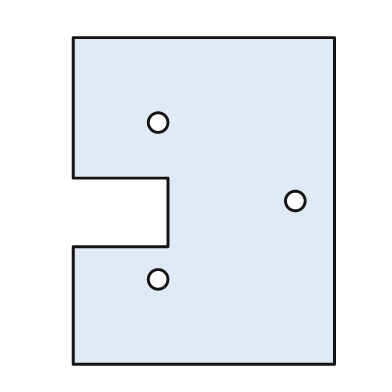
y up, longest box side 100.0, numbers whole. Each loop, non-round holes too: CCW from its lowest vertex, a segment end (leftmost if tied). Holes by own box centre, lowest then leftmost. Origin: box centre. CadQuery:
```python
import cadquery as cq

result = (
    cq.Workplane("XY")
    .moveTo(-40.0, -50.0)
    .lineTo(40.0, -50.0)
    .lineTo(40.0, 50.0)
    .lineTo(-40.0, 50.0)
    .lineTo(-40.0, 7.0)
    .lineTo(-11.0, 7.0)
    .lineTo(-11.0, -14.0)
    .lineTo(-40.0, -14.0)
    .close()
    .moveTo(-14.0, -24.0)
    .circle(3.0)
    .moveTo(28.0, 0.0)
    .circle(3.0)
    .moveTo(-14.0, 24.0)
    .circle(3.0)
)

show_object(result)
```